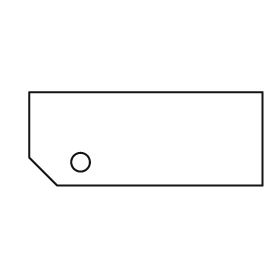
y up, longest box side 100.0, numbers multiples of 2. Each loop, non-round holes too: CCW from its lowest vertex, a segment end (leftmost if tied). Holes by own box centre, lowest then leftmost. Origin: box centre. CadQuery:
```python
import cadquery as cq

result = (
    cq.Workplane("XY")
    .moveTo(-38.0, -20.0)
    .lineTo(50.0, -20.0)
    .lineTo(50.0, 20.0)
    .lineTo(-50.0, 20.0)
    .lineTo(-50.0, -8.0)
    .close()
    .moveTo(-28.0, -10.0)
    .circle(4.0)
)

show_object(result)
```